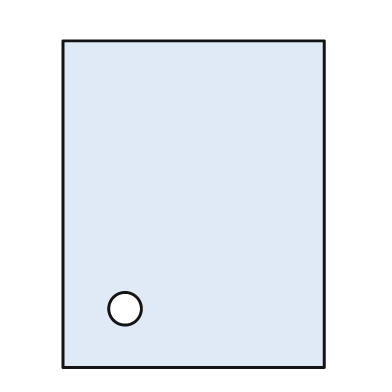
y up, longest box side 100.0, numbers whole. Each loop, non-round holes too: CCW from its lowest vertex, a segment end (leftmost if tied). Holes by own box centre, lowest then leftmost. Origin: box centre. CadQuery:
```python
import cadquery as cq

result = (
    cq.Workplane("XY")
    .moveTo(-40.0, -50.0)
    .lineTo(40.0, -50.0)
    .lineTo(40.0, 50.0)
    .lineTo(-40.0, 50.0)
    .close()
    .moveTo(-21.0, -32.0)
    .circle(5.0)
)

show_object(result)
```